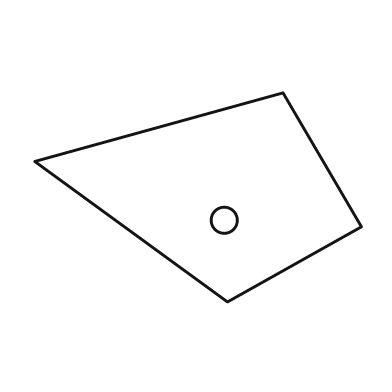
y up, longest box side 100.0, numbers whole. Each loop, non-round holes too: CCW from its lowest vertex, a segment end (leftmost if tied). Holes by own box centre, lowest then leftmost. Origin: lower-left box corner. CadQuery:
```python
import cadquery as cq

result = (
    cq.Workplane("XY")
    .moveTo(59.0, 0.0)
    .lineTo(100.0, 23.0)
    .lineTo(76.0, 64.0)
    .lineTo(0.0, 43.0)
    .close()
    .moveTo(58.0, 25.0)
    .circle(4.0)
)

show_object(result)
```